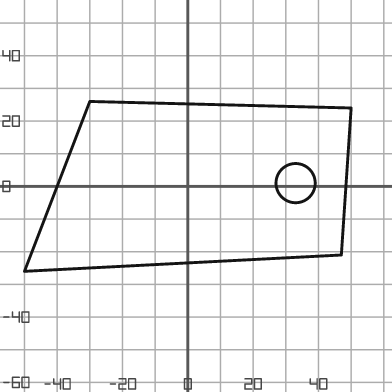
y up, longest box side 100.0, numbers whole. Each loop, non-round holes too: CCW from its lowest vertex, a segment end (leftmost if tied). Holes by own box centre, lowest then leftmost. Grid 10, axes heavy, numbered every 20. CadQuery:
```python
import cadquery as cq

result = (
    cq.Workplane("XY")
    .moveTo(-50.0, -26.0)
    .lineTo(47.0, -21.0)
    .lineTo(50.0, 24.0)
    .lineTo(-30.0, 26.0)
    .close()
    .moveTo(33.0, 1.0)
    .circle(6.0)
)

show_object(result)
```